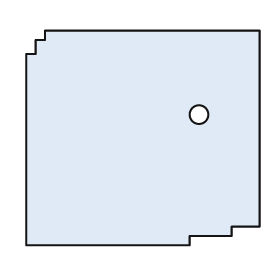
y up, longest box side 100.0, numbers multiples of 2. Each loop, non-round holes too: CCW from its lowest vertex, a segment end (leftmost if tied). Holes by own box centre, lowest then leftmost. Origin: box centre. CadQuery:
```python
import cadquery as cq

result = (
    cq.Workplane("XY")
    .moveTo(-50.0, -46.0)
    .lineTo(20.0, -46.0)
    .lineTo(20.0, -42.0)
    .lineTo(38.0, -42.0)
    .lineTo(38.0, -38.0)
    .lineTo(50.0, -38.0)
    .lineTo(50.0, 46.0)
    .lineTo(-42.0, 46.0)
    .lineTo(-42.0, 42.0)
    .lineTo(-46.0, 42.0)
    .lineTo(-46.0, 36.0)
    .lineTo(-50.0, 36.0)
    .close()
    .moveTo(24.0, 10.0)
    .circle(4.0)
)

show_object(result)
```